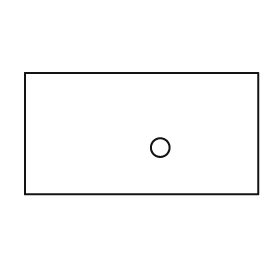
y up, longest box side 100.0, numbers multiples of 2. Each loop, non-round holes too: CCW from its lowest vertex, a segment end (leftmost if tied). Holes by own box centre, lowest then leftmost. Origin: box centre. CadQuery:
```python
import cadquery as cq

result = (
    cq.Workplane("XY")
    .moveTo(-50.0, -26.0)
    .lineTo(50.0, -26.0)
    .lineTo(50.0, 26.0)
    .lineTo(-50.0, 26.0)
    .close()
    .moveTo(8.0, -6.0)
    .circle(4.0)
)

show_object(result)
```